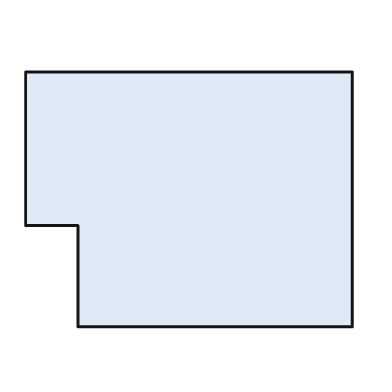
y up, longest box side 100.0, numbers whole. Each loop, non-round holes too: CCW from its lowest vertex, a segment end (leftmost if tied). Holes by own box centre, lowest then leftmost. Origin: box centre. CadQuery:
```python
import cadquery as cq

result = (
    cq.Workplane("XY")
    .moveTo(-34.0, -39.0)
    .lineTo(50.0, -39.0)
    .lineTo(50.0, 39.0)
    .lineTo(-50.0, 39.0)
    .lineTo(-50.0, -8.0)
    .lineTo(-34.0, -8.0)
    .close()
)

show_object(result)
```